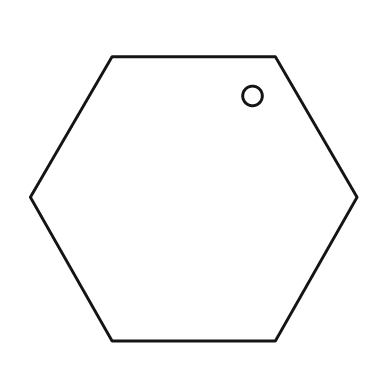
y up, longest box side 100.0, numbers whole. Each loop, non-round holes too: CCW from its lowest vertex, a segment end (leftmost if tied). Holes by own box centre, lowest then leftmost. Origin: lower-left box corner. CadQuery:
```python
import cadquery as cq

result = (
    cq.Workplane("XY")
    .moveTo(25.0, 0.0)
    .lineTo(75.0, 0.0)
    .lineTo(100.0, 44.0)
    .lineTo(75.0, 87.0)
    .lineTo(25.0, 87.0)
    .lineTo(0.0, 44.0)
    .close()
    .moveTo(68.0, 75.0)
    .circle(3.0)
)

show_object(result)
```